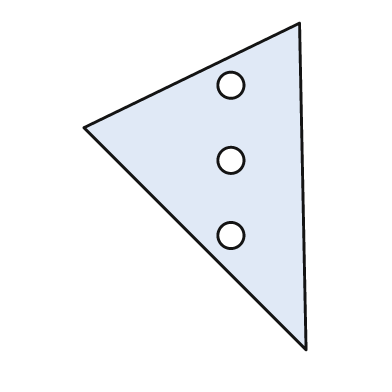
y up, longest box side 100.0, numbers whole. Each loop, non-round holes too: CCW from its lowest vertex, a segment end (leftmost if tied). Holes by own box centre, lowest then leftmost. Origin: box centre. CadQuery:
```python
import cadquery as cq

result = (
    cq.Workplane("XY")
    .moveTo(34.0, -50.0)
    .lineTo(32.0, 50.0)
    .lineTo(-34.0, 18.0)
    .close()
    .moveTo(11.0, -15.0)
    .circle(4.0)
    .moveTo(11.0, 8.0)
    .circle(4.0)
    .moveTo(11.0, 31.0)
    .circle(4.0)
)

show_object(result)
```